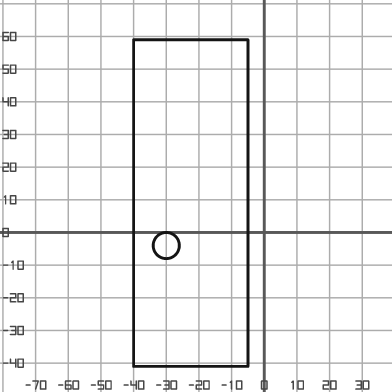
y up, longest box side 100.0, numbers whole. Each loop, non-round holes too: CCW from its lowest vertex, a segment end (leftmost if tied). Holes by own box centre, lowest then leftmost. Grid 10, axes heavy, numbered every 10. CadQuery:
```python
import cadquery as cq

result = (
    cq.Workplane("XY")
    .moveTo(-40.0, -41.0)
    .lineTo(-5.0, -41.0)
    .lineTo(-5.0, 59.0)
    .lineTo(-40.0, 59.0)
    .close()
    .moveTo(-30.0, -4.0)
    .circle(4.0)
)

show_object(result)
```